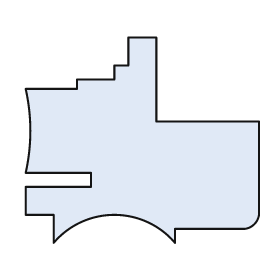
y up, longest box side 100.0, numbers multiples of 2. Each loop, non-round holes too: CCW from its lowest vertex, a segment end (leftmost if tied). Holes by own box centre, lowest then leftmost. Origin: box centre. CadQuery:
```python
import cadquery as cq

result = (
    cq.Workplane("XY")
    .moveTo(-38.0, -44.0)
    .threePointArc((-12.0, -32.0), (14.0, -44.0))
    .lineTo(14.0, -38.0)
    .lineTo(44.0, -38.0)
    .threePointArc((48.0, -36.0), (50.0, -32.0))
    .lineTo(50.0, 8.0)
    .lineTo(6.0, 8.0)
    .lineTo(6.0, 44.0)
    .lineTo(-6.0, 44.0)
    .lineTo(-6.0, 32.0)
    .lineTo(-12.0, 32.0)
    .lineTo(-12.0, 26.0)
    .lineTo(-28.0, 26.0)
    .lineTo(-28.0, 22.0)
    .lineTo(-50.0, 22.0)
    .threePointArc((-48.0, 4.0), (-50.0, -14.0))
    .lineTo(-22.0, -14.0)
    .lineTo(-22.0, -20.0)
    .lineTo(-50.0, -20.0)
    .lineTo(-50.0, -32.0)
    .lineTo(-38.0, -32.0)
    .close()
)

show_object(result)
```